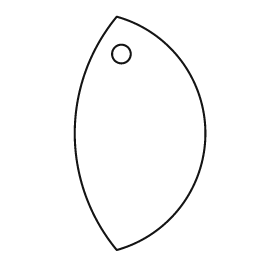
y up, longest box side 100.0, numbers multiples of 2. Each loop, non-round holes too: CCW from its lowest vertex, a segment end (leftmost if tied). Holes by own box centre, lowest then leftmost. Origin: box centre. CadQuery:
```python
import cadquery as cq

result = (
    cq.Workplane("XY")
    .moveTo(-10.0, -50.0)
    .threePointArc((28.0, 0.0), (-10.0, 50.0))
    .threePointArc((-28.0, 0.0), (-10.0, -50.0))
    .close()
    .moveTo(-8.0, 34.0)
    .circle(4.0)
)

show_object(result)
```